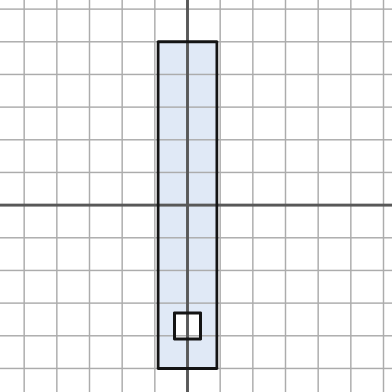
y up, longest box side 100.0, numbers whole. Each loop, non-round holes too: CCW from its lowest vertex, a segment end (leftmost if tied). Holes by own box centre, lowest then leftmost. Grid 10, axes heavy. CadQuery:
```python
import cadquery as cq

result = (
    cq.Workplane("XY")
    .moveTo(-9.0, -50.0)
    .lineTo(9.0, -50.0)
    .lineTo(9.0, 50.0)
    .lineTo(-9.0, 50.0)
    .close()
    .moveTo(-4.0, -41.0)
    .lineTo(4.0, -41.0)
    .lineTo(4.0, -33.0)
    .lineTo(-4.0, -33.0)
    .close()
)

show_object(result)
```